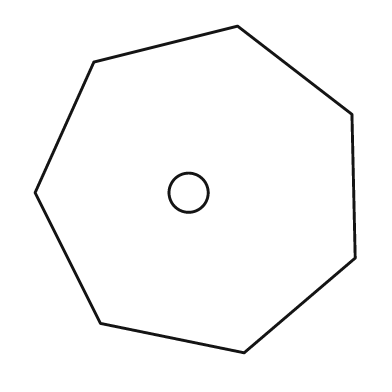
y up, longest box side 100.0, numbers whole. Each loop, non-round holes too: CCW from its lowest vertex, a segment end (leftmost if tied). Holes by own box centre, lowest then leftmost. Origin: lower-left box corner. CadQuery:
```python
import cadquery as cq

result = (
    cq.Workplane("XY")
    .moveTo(64.0, 0.0)
    .lineTo(98.0, 29.0)
    .lineTo(97.0, 73.0)
    .lineTo(62.0, 100.0)
    .lineTo(18.0, 89.0)
    .lineTo(0.0, 49.0)
    .lineTo(20.0, 9.0)
    .close()
    .moveTo(47.0, 49.0)
    .circle(6.0)
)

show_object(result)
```